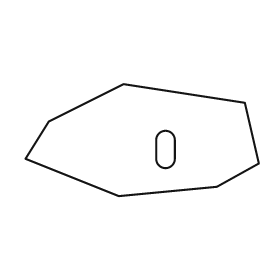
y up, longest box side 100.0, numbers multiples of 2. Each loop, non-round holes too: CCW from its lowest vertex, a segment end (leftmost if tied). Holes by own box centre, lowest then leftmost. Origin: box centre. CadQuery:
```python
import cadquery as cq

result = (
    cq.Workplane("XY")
    .moveTo(-10.0, -24.0)
    .lineTo(32.0, -20.0)
    .lineTo(50.0, -10.0)
    .lineTo(44.0, 16.0)
    .lineTo(-8.0, 24.0)
    .lineTo(-40.0, 8.0)
    .lineTo(-50.0, -8.0)
    .close()
    .moveTo(6.0, -8.0)
    .threePointArc((10.0, -12.0), (14.0, -8.0))
    .lineTo(14.0, 0.0)
    .threePointArc((10.0, 4.0), (6.0, 0.0))
    .close()
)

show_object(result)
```